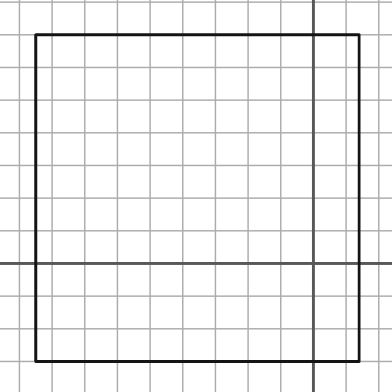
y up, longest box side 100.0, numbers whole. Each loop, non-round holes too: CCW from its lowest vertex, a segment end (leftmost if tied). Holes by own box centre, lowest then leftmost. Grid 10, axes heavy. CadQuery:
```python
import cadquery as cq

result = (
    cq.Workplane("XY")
    .moveTo(-85.0, -30.0)
    .lineTo(14.0, -30.0)
    .lineTo(14.0, 70.0)
    .lineTo(-85.0, 70.0)
    .close()
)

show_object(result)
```